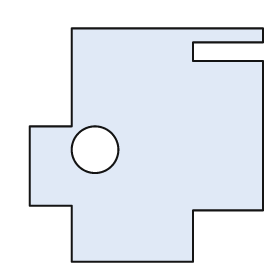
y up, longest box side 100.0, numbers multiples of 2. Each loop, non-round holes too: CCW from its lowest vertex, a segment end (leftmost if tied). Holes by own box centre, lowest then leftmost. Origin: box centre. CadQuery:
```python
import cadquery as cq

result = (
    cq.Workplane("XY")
    .moveTo(-32.0, -50.0)
    .lineTo(20.0, -50.0)
    .lineTo(20.0, -28.0)
    .lineTo(50.0, -28.0)
    .lineTo(50.0, 36.0)
    .lineTo(20.0, 36.0)
    .lineTo(20.0, 44.0)
    .lineTo(50.0, 44.0)
    .lineTo(50.0, 50.0)
    .lineTo(-32.0, 50.0)
    .lineTo(-32.0, 8.0)
    .lineTo(-50.0, 8.0)
    .lineTo(-50.0, -26.0)
    .lineTo(-32.0, -26.0)
    .close()
    .moveTo(-22.0, -2.0)
    .circle(10.0)
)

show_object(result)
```